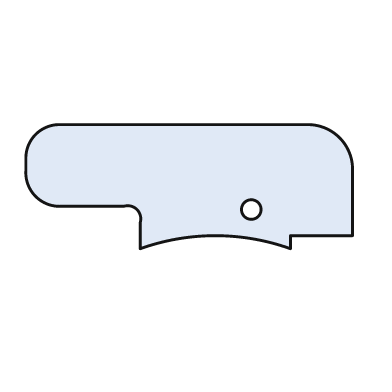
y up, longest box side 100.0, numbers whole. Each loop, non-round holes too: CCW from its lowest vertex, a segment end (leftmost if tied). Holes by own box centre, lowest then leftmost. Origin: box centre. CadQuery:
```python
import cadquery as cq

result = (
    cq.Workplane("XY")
    .moveTo(-15.0, -19.0)
    .threePointArc((8.0, -15.0), (31.0, -19.0))
    .lineTo(31.0, -15.0)
    .lineTo(50.0, -15.0)
    .lineTo(50.0, 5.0)
    .threePointArc((46.0, 15.0), (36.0, 19.0))
    .lineTo(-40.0, 19.0)
    .threePointArc((-47.0, 16.0), (-50.0, 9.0))
    .lineTo(-50.0, 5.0)
    .threePointArc((-47.0, -3.0), (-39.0, -6.0))
    .lineTo(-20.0, -6.0)
    .threePointArc((-16.0, -7.0), (-15.0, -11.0))
    .close()
    .moveTo(19.0, -7.0)
    .circle(3.0)
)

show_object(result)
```